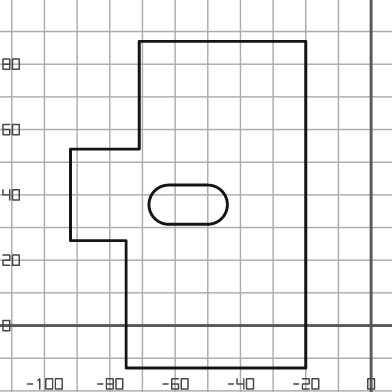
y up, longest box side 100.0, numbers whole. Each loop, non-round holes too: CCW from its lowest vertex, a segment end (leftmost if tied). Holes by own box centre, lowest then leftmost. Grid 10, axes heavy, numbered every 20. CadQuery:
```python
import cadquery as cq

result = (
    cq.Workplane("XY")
    .moveTo(-75.0, -13.0)
    .lineTo(-20.0, -13.0)
    .lineTo(-20.0, 87.0)
    .lineTo(-71.0, 87.0)
    .lineTo(-71.0, 54.0)
    .lineTo(-92.0, 54.0)
    .lineTo(-92.0, 26.0)
    .lineTo(-75.0, 26.0)
    .close()
    .moveTo(-62.0, 31.0)
    .lineTo(-50.0, 31.0)
    .threePointArc((-44.0, 37.0), (-50.0, 43.0))
    .lineTo(-62.0, 43.0)
    .threePointArc((-68.0, 37.0), (-62.0, 31.0))
    .close()
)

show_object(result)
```